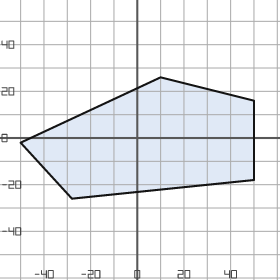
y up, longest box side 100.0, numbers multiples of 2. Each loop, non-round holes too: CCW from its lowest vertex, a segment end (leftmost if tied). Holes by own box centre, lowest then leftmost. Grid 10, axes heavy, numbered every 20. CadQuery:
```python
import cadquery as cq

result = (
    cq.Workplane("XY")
    .moveTo(-28.0, -26.0)
    .lineTo(50.0, -18.0)
    .lineTo(50.0, 16.0)
    .lineTo(10.0, 26.0)
    .lineTo(-50.0, -2.0)
    .close()
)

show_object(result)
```